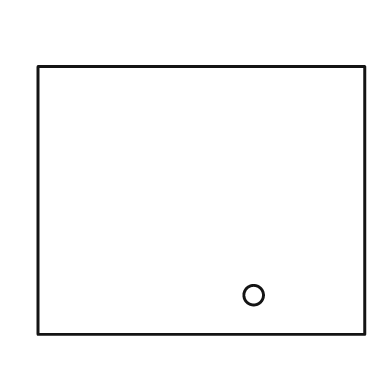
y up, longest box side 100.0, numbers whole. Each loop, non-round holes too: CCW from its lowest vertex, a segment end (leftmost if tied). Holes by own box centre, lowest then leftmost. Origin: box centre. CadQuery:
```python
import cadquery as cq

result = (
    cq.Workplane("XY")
    .moveTo(-50.0, -41.0)
    .lineTo(50.0, -41.0)
    .lineTo(50.0, 41.0)
    .lineTo(-50.0, 41.0)
    .close()
    .moveTo(16.0, -29.0)
    .circle(3.0)
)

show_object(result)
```